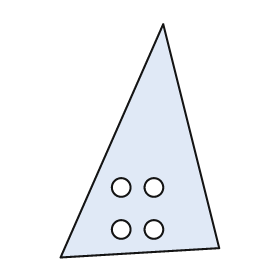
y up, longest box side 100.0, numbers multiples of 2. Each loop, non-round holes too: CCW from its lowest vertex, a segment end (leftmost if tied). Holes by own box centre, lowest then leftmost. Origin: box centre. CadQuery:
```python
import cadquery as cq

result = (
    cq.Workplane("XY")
    .moveTo(-34.0, -50.0)
    .lineTo(34.0, -46.0)
    .lineTo(10.0, 50.0)
    .close()
    .moveTo(-8.0, -38.0)
    .circle(4.0)
    .moveTo(6.0, -38.0)
    .circle(4.0)
    .moveTo(-8.0, -20.0)
    .circle(4.0)
    .moveTo(6.0, -20.0)
    .circle(4.0)
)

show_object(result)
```